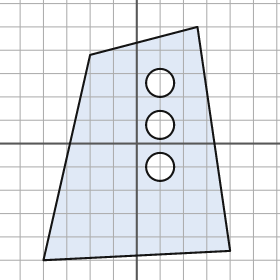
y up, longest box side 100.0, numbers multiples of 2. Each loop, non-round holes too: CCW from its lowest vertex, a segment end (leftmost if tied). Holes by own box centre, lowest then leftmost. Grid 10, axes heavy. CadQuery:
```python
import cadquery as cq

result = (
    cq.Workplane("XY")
    .moveTo(-40.0, -50.0)
    .lineTo(40.0, -46.0)
    .lineTo(26.0, 50.0)
    .lineTo(-20.0, 38.0)
    .close()
    .moveTo(10.0, -10.0)
    .circle(6.0)
    .moveTo(10.0, 8.0)
    .circle(6.0)
    .moveTo(10.0, 26.0)
    .circle(6.0)
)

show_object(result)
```